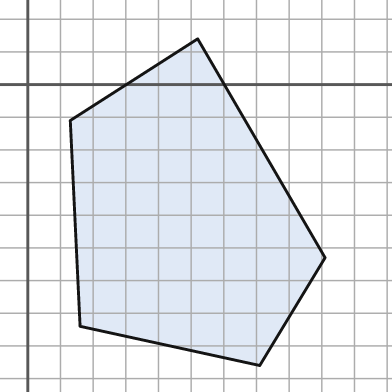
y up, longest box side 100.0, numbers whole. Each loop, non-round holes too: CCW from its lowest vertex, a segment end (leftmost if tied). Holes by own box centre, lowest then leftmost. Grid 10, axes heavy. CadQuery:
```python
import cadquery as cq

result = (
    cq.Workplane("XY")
    .moveTo(71.0, -86.0)
    .lineTo(91.0, -53.0)
    .lineTo(52.0, 14.0)
    .lineTo(13.0, -11.0)
    .lineTo(16.0, -74.0)
    .close()
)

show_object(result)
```